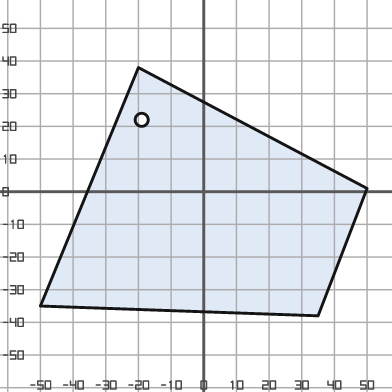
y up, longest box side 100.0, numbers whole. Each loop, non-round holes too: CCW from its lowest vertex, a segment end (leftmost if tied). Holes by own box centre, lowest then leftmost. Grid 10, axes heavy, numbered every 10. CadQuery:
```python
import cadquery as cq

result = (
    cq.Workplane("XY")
    .moveTo(35.0, -38.0)
    .lineTo(50.0, 1.0)
    .lineTo(-20.0, 38.0)
    .lineTo(-50.0, -35.0)
    .close()
    .moveTo(-19.0, 22.0)
    .circle(2.0)
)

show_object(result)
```